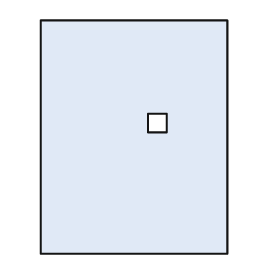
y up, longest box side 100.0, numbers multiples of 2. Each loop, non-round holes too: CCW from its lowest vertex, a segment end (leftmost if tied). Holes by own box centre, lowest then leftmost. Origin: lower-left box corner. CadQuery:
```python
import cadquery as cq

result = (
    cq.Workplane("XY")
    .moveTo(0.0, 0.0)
    .lineTo(80.0, 0.0)
    .lineTo(80.0, 100.0)
    .lineTo(0.0, 100.0)
    .close()
    .moveTo(46.0, 52.0)
    .lineTo(54.0, 52.0)
    .lineTo(54.0, 60.0)
    .lineTo(46.0, 60.0)
    .close()
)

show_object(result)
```